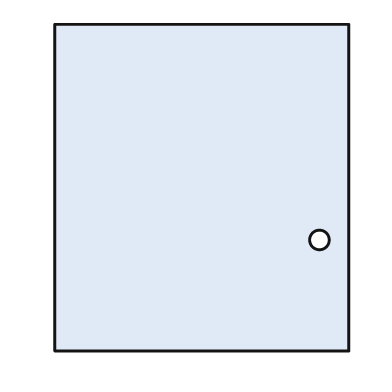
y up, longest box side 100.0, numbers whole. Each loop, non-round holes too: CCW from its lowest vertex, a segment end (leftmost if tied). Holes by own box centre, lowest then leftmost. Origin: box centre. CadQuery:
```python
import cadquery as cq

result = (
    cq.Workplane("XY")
    .moveTo(-45.0, -50.0)
    .lineTo(45.0, -50.0)
    .lineTo(45.0, 50.0)
    .lineTo(-45.0, 50.0)
    .close()
    .moveTo(36.0, -16.0)
    .circle(3.0)
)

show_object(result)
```